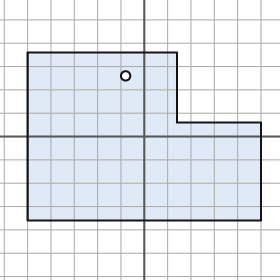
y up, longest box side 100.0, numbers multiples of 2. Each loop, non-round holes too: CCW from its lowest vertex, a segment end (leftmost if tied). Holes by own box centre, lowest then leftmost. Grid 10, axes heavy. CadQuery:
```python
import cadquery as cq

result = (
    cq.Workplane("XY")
    .moveTo(-50.0, -36.0)
    .lineTo(50.0, -36.0)
    .lineTo(50.0, 6.0)
    .lineTo(14.0, 6.0)
    .lineTo(14.0, 36.0)
    .lineTo(-50.0, 36.0)
    .close()
    .moveTo(-8.0, 26.0)
    .circle(2.0)
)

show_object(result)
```